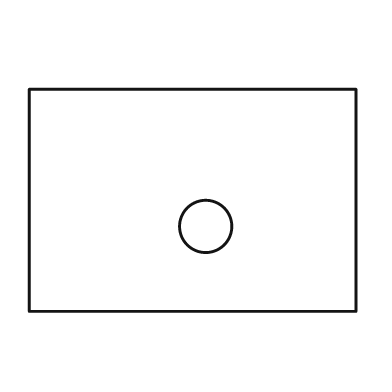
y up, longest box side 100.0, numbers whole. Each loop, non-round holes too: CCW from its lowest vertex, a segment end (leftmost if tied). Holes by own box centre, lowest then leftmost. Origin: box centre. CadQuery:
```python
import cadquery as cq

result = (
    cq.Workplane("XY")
    .moveTo(-50.0, -34.0)
    .lineTo(50.0, -34.0)
    .lineTo(50.0, 34.0)
    .lineTo(-50.0, 34.0)
    .close()
    .moveTo(4.0, -8.0)
    .circle(8.0)
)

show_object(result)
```